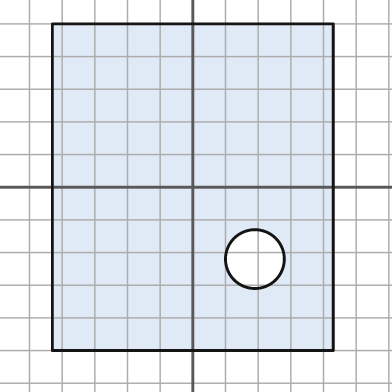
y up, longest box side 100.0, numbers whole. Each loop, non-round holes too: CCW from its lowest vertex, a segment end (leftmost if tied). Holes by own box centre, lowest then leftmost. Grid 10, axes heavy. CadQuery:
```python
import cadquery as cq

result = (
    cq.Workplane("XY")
    .moveTo(-43.0, -50.0)
    .lineTo(43.0, -50.0)
    .lineTo(43.0, 50.0)
    .lineTo(-43.0, 50.0)
    .close()
    .moveTo(19.0, -22.0)
    .circle(9.0)
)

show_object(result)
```